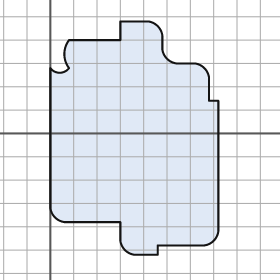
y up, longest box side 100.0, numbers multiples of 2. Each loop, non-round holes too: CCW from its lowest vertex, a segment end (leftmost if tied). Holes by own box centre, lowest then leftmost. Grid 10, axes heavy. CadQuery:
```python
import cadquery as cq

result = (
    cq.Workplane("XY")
    .moveTo(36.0, -52.0)
    .lineTo(46.0, -52.0)
    .lineTo(46.0, -48.0)
    .lineTo(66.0, -48.0)
    .threePointArc((70.0, -46.0), (72.0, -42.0))
    .lineTo(72.0, 14.0)
    .lineTo(68.0, 14.0)
    .lineTo(68.0, 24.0)
    .threePointArc((66.0, 28.0), (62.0, 30.0))
    .lineTo(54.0, 30.0)
    .threePointArc((50.0, 32.0), (48.0, 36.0))
    .lineTo(48.0, 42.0)
    .threePointArc((46.0, 46.0), (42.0, 48.0))
    .lineTo(30.0, 48.0)
    .lineTo(30.0, 40.0)
    .lineTo(8.0, 40.0)
    .threePointArc((6.0, 34.0), (8.0, 28.0))
    .threePointArc((4.0, 26.0), (0.0, 28.0))
    .lineTo(0.0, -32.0)
    .threePointArc((2.0, -36.0), (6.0, -38.0))
    .lineTo(30.0, -38.0)
    .lineTo(30.0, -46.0)
    .threePointArc((32.0, -50.0), (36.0, -52.0))
    .close()
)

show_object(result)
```